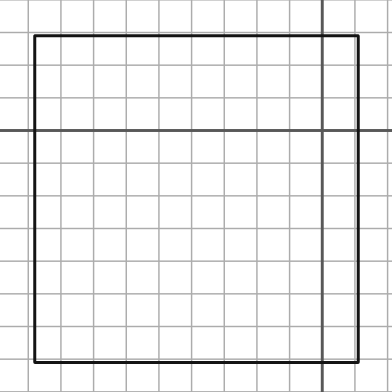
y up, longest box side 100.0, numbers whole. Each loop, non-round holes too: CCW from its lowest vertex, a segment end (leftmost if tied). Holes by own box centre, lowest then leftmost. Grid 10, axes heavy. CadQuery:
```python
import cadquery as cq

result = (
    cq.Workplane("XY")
    .moveTo(-88.0, -71.0)
    .lineTo(11.0, -71.0)
    .lineTo(11.0, 29.0)
    .lineTo(-88.0, 29.0)
    .close()
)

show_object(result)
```